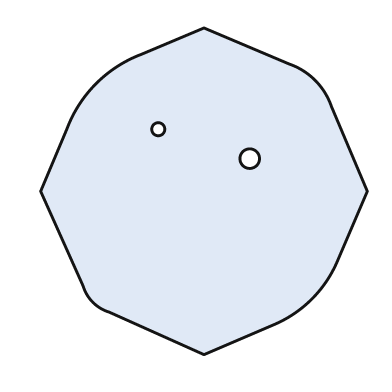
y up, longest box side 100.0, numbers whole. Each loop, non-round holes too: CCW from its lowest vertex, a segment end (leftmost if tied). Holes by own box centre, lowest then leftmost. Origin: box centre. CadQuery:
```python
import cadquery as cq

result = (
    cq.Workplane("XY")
    .moveTo(0.0, -50.0)
    .lineTo(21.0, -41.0)
    .threePointArc((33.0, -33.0), (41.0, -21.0))
    .lineTo(50.0, 0.0)
    .lineTo(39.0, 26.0)
    .threePointArc((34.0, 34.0), (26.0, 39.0))
    .lineTo(0.0, 50.0)
    .lineTo(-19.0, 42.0)
    .threePointArc((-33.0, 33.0), (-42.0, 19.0))
    .lineTo(-50.0, 0.0)
    .lineTo(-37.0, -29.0)
    .threePointArc((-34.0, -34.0), (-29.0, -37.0))
    .close()
    .moveTo(14.0, 10.0)
    .circle(3.0)
    .moveTo(-14.0, 19.0)
    .circle(2.0)
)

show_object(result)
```